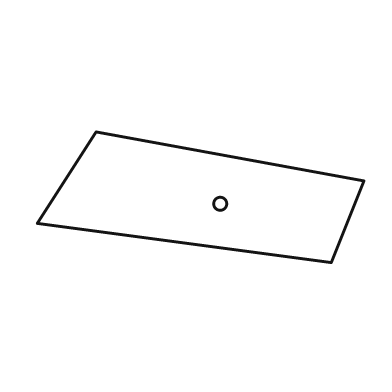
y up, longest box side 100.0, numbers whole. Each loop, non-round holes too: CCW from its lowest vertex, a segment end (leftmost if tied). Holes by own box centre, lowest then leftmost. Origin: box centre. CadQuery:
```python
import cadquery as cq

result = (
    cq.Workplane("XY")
    .moveTo(40.0, -20.0)
    .lineTo(50.0, 5.0)
    .lineTo(-32.0, 20.0)
    .lineTo(-50.0, -8.0)
    .close()
    .moveTo(6.0, -2.0)
    .circle(2.0)
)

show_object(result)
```